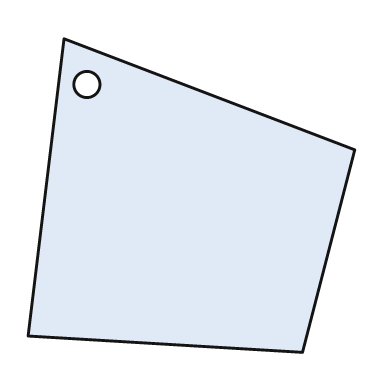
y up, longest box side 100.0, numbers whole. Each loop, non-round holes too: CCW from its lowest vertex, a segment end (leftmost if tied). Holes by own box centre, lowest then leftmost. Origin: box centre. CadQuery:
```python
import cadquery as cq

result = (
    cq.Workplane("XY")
    .moveTo(34.0, -48.0)
    .lineTo(50.0, 14.0)
    .lineTo(-39.0, 48.0)
    .lineTo(-50.0, -43.0)
    .close()
    .moveTo(-32.0, 34.0)
    .circle(4.0)
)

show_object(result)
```